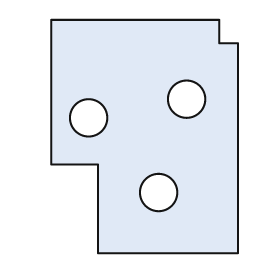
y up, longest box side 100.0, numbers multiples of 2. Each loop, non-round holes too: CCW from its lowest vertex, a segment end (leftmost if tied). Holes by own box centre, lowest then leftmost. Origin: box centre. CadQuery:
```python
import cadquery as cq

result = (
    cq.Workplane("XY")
    .moveTo(-20.0, -50.0)
    .lineTo(40.0, -50.0)
    .lineTo(40.0, 40.0)
    .lineTo(32.0, 40.0)
    .lineTo(32.0, 50.0)
    .lineTo(-40.0, 50.0)
    .lineTo(-40.0, -12.0)
    .lineTo(-20.0, -12.0)
    .close()
    .moveTo(6.0, -24.0)
    .circle(8.0)
    .moveTo(-24.0, 8.0)
    .circle(8.0)
    .moveTo(18.0, 16.0)
    .circle(8.0)
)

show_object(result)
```